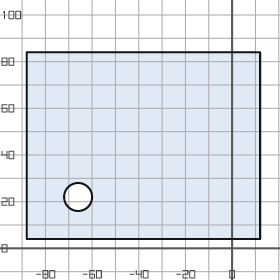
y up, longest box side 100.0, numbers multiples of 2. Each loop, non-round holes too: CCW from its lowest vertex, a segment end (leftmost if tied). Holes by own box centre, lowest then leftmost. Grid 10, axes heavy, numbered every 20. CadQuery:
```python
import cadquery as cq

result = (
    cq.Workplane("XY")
    .moveTo(-88.0, 4.0)
    .lineTo(12.0, 4.0)
    .lineTo(12.0, 84.0)
    .lineTo(-88.0, 84.0)
    .close()
    .moveTo(-66.0, 22.0)
    .circle(6.0)
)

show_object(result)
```